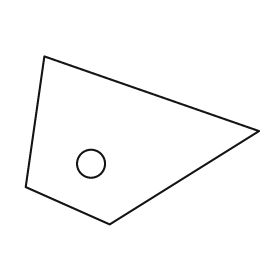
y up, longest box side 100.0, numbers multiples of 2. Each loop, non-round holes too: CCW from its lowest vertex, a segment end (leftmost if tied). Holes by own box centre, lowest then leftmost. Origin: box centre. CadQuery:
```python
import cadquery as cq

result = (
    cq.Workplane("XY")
    .moveTo(-14.0, -36.0)
    .lineTo(50.0, 4.0)
    .lineTo(-42.0, 36.0)
    .lineTo(-50.0, -20.0)
    .close()
    .moveTo(-22.0, -10.0)
    .circle(6.0)
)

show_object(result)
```